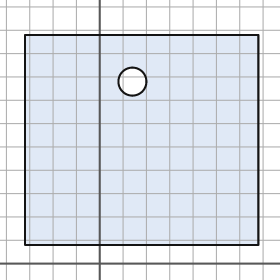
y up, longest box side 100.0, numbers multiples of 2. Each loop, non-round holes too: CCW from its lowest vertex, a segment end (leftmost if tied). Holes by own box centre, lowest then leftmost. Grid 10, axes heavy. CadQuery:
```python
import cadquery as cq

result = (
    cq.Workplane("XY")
    .moveTo(-32.0, 8.0)
    .lineTo(68.0, 8.0)
    .lineTo(68.0, 98.0)
    .lineTo(-32.0, 98.0)
    .close()
    .moveTo(14.0, 78.0)
    .circle(6.0)
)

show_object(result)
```